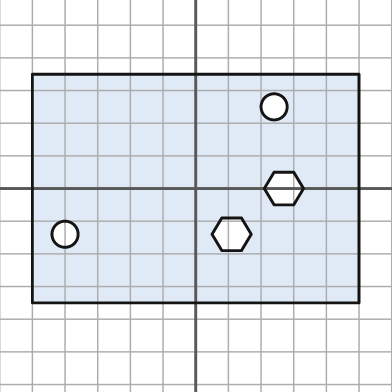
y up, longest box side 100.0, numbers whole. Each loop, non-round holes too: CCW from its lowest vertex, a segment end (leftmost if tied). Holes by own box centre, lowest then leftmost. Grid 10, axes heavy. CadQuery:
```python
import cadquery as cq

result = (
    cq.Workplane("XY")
    .moveTo(-50.0, -35.0)
    .lineTo(50.0, -35.0)
    .lineTo(50.0, 35.0)
    .lineTo(-50.0, 35.0)
    .close()
    .moveTo(-40.0, -14.0)
    .circle(4.0)
    .moveTo(8.0, -19.0)
    .lineTo(14.0, -19.0)
    .lineTo(17.0, -14.0)
    .lineTo(14.0, -9.0)
    .lineTo(8.0, -9.0)
    .lineTo(5.0, -14.0)
    .close()
    .moveTo(24.0, -5.0)
    .lineTo(30.0, -5.0)
    .lineTo(33.0, 0.0)
    .lineTo(30.0, 5.0)
    .lineTo(24.0, 5.0)
    .lineTo(21.0, 0.0)
    .close()
    .moveTo(24.0, 25.0)
    .circle(4.0)
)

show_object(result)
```